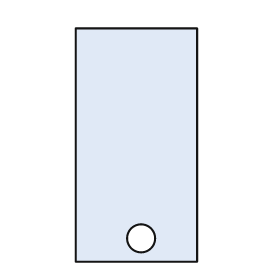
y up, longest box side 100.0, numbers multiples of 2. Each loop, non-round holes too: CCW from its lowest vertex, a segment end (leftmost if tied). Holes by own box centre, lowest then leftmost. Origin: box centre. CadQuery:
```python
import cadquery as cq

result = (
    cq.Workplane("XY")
    .moveTo(-26.0, -50.0)
    .lineTo(26.0, -50.0)
    .lineTo(26.0, 50.0)
    .lineTo(-26.0, 50.0)
    .close()
    .moveTo(2.0, -40.0)
    .circle(6.0)
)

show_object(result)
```